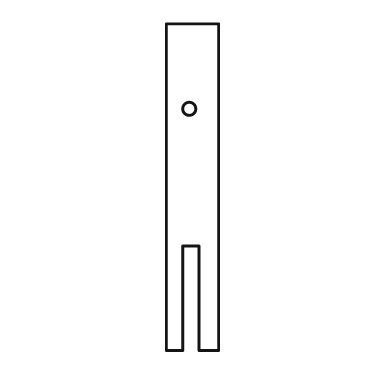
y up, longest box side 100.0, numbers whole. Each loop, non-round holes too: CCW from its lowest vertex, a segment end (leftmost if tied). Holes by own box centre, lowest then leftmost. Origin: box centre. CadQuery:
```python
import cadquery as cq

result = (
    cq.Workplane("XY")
    .moveTo(-8.0, -50.0)
    .lineTo(-3.0, -50.0)
    .lineTo(-3.0, -18.0)
    .lineTo(2.0, -18.0)
    .lineTo(2.0, -50.0)
    .lineTo(8.0, -50.0)
    .lineTo(8.0, 50.0)
    .lineTo(-8.0, 50.0)
    .close()
    .moveTo(-1.0, 24.0)
    .circle(2.0)
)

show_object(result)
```